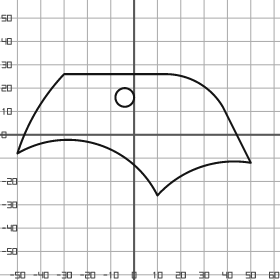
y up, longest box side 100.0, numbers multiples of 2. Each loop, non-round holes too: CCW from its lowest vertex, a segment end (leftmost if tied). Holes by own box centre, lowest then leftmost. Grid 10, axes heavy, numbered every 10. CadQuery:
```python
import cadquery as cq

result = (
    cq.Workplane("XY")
    .moveTo(10.0, -26.0)
    .threePointArc((28.0, -14.0), (50.0, -12.0))
    .lineTo(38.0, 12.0)
    .threePointArc((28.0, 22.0), (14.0, 26.0))
    .lineTo(-30.0, 26.0)
    .threePointArc((-42.0, 10.0), (-50.0, -8.0))
    .threePointArc((-16.0, -4.0), (10.0, -26.0))
    .close()
    .moveTo(-4.0, 16.0)
    .circle(4.0)
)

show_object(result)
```